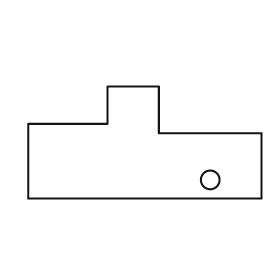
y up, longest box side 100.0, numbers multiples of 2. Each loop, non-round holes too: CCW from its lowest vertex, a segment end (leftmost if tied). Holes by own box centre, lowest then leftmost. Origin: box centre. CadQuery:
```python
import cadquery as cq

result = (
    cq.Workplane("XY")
    .moveTo(-50.0, -24.0)
    .lineTo(50.0, -24.0)
    .lineTo(50.0, 4.0)
    .lineTo(6.0, 4.0)
    .lineTo(6.0, 24.0)
    .lineTo(-16.0, 24.0)
    .lineTo(-16.0, 8.0)
    .lineTo(-50.0, 8.0)
    .close()
    .moveTo(28.0, -16.0)
    .circle(4.0)
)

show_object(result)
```